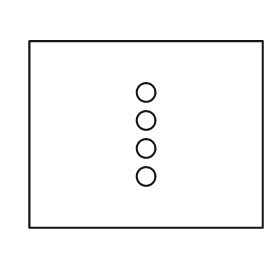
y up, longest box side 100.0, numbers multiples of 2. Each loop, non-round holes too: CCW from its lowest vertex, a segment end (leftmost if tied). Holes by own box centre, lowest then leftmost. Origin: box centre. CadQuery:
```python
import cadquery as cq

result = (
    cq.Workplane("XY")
    .moveTo(-50.0, -40.0)
    .lineTo(50.0, -40.0)
    .lineTo(50.0, 40.0)
    .lineTo(-50.0, 40.0)
    .close()
    .moveTo(0.0, -18.0)
    .circle(4.0)
    .moveTo(0.0, -6.0)
    .circle(4.0)
    .moveTo(0.0, 6.0)
    .circle(4.0)
    .moveTo(0.0, 18.0)
    .circle(4.0)
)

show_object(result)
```